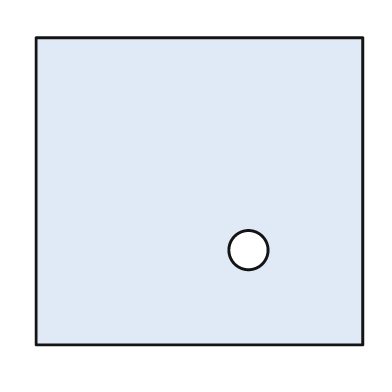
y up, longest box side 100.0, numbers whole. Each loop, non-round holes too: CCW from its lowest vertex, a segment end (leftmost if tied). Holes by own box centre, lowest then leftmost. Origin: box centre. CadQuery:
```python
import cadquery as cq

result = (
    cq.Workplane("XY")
    .moveTo(-50.0, -47.0)
    .lineTo(50.0, -47.0)
    .lineTo(50.0, 47.0)
    .lineTo(-50.0, 47.0)
    .close()
    .moveTo(15.0, -18.0)
    .circle(6.0)
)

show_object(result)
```